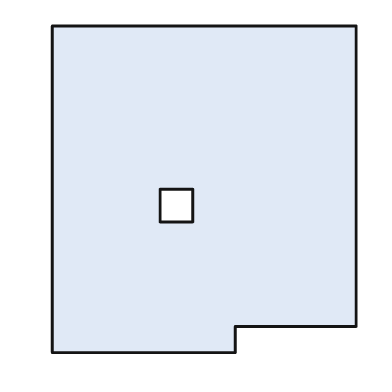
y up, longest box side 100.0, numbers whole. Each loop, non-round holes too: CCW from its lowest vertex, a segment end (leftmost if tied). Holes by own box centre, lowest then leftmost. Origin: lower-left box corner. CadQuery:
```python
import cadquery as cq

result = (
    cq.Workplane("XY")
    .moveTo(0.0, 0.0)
    .lineTo(56.0, 0.0)
    .lineTo(56.0, 8.0)
    .lineTo(93.0, 8.0)
    .lineTo(93.0, 100.0)
    .lineTo(0.0, 100.0)
    .close()
    .moveTo(33.0, 40.0)
    .lineTo(43.0, 40.0)
    .lineTo(43.0, 50.0)
    .lineTo(33.0, 50.0)
    .close()
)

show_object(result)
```